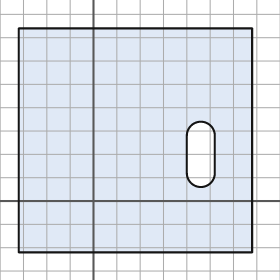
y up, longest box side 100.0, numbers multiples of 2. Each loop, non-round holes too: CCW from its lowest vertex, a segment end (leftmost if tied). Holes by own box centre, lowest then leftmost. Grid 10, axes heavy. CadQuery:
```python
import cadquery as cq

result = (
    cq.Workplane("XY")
    .moveTo(-32.0, -22.0)
    .lineTo(68.0, -22.0)
    .lineTo(68.0, 74.0)
    .lineTo(-32.0, 74.0)
    .close()
    .moveTo(40.0, 12.0)
    .threePointArc((46.0, 6.0), (52.0, 12.0))
    .lineTo(52.0, 28.0)
    .threePointArc((46.0, 34.0), (40.0, 28.0))
    .close()
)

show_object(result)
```